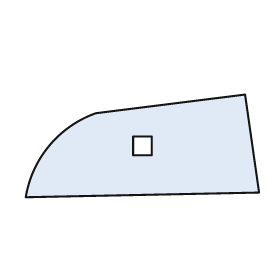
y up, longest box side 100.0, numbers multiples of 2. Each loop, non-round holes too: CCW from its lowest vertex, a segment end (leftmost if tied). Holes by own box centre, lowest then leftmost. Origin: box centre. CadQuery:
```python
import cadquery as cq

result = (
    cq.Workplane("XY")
    .moveTo(-50.0, -22.0)
    .lineTo(50.0, -20.0)
    .lineTo(44.0, 22.0)
    .lineTo(-20.0, 14.0)
    .threePointArc((-40.0, 0.0), (-50.0, -22.0))
    .close()
    .moveTo(-4.0, -4.0)
    .lineTo(4.0, -4.0)
    .lineTo(4.0, 4.0)
    .lineTo(-4.0, 4.0)
    .close()
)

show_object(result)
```